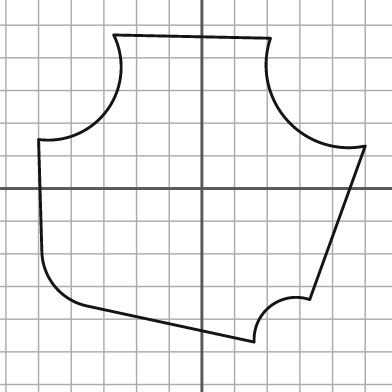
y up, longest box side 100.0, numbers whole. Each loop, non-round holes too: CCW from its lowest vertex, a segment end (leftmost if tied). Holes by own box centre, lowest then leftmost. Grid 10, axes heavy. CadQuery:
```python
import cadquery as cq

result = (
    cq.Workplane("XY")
    .moveTo(16.0, -47.0)
    .threePointArc((21.0, -36.0), (33.0, -34.0))
    .lineTo(50.0, 13.0)
    .threePointArc((26.0, 21.0), (21.0, 46.0))
    .lineTo(-27.0, 47.0)
    .threePointArc((-29.0, 24.0), (-50.0, 15.0))
    .lineTo(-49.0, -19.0)
    .threePointArc((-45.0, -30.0), (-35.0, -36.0))
    .close()
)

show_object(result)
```